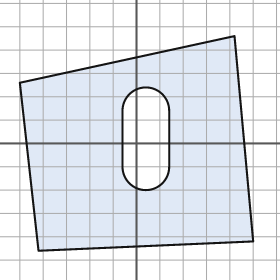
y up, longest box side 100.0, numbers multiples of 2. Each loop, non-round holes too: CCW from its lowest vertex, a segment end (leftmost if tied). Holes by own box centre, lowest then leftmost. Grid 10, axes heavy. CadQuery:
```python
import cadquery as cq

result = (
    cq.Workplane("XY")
    .moveTo(-42.0, -46.0)
    .lineTo(50.0, -42.0)
    .lineTo(42.0, 46.0)
    .lineTo(-50.0, 26.0)
    .close()
    .moveTo(-6.0, -10.0)
    .threePointArc((4.0, -20.0), (14.0, -10.0))
    .lineTo(14.0, 14.0)
    .threePointArc((4.0, 24.0), (-6.0, 14.0))
    .close()
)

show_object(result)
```